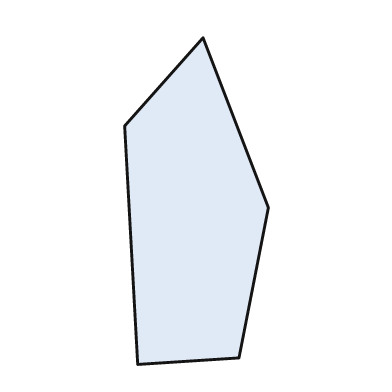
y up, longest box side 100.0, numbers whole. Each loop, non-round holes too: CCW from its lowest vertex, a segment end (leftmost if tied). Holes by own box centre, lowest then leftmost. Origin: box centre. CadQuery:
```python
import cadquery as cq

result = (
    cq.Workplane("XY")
    .moveTo(-18.0, -50.0)
    .lineTo(13.0, -48.0)
    .lineTo(22.0, -2.0)
    .lineTo(2.0, 50.0)
    .lineTo(-22.0, 23.0)
    .close()
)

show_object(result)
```